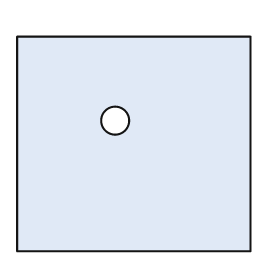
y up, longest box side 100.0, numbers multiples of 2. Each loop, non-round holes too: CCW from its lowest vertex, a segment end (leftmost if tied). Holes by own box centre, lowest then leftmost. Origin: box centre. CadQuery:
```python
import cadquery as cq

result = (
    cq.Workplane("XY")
    .moveTo(-50.0, -46.0)
    .lineTo(50.0, -46.0)
    .lineTo(50.0, 46.0)
    .lineTo(-50.0, 46.0)
    .close()
    .moveTo(-8.0, 10.0)
    .circle(6.0)
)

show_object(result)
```